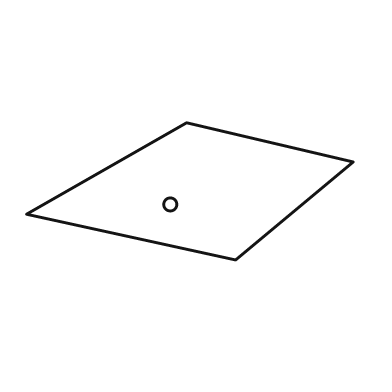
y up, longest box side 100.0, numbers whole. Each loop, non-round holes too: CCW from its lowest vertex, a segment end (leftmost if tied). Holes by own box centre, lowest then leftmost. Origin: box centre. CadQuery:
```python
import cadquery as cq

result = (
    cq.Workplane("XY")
    .moveTo(14.0, -21.0)
    .lineTo(50.0, 9.0)
    .lineTo(-1.0, 21.0)
    .lineTo(-50.0, -7.0)
    .close()
    .moveTo(-6.0, -4.0)
    .circle(2.0)
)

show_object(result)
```